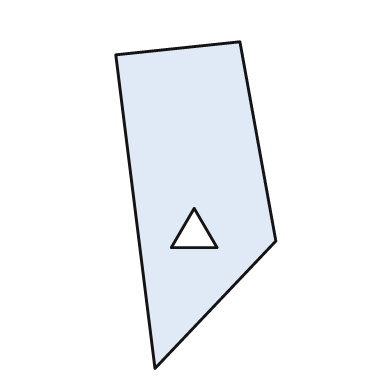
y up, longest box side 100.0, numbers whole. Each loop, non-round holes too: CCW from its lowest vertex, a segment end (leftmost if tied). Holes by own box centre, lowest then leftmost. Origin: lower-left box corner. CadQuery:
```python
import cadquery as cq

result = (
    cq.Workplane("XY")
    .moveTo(12.0, 0.0)
    .lineTo(49.0, 39.0)
    .lineTo(38.0, 100.0)
    .lineTo(0.0, 96.0)
    .close()
    .moveTo(17.0, 37.0)
    .lineTo(31.0, 37.0)
    .lineTo(24.0, 49.0)
    .close()
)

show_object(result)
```